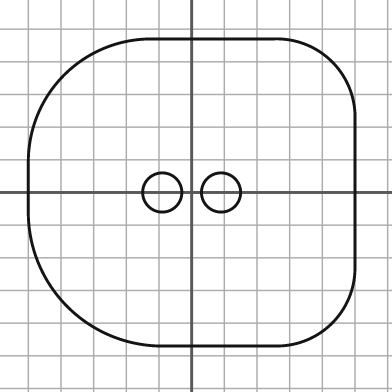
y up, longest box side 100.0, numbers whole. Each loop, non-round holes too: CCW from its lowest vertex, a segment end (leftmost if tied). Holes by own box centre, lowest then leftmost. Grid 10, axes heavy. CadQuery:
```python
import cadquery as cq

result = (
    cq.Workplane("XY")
    .moveTo(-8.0, -47.0)
    .lineTo(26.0, -47.0)
    .threePointArc((43.0, -40.0), (50.0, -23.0))
    .lineTo(50.0, 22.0)
    .threePointArc((43.0, 40.0), (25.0, 47.0))
    .lineTo(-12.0, 47.0)
    .threePointArc((-39.0, 36.0), (-50.0, 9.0))
    .lineTo(-50.0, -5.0)
    .threePointArc((-38.0, -35.0), (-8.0, -47.0))
    .close()
    .moveTo(-9.0, 0.0)
    .circle(6.0)
    .moveTo(9.0, 0.0)
    .circle(6.0)
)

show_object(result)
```